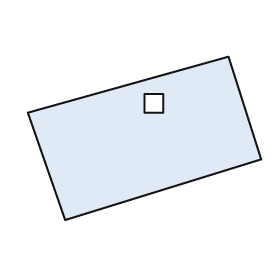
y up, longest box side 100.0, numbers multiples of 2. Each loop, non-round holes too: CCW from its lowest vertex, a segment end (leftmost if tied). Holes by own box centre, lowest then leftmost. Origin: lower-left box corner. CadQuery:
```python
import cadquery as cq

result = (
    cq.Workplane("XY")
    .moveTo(16.0, 0.0)
    .lineTo(100.0, 26.0)
    .lineTo(86.0, 70.0)
    .lineTo(0.0, 46.0)
    .close()
    .moveTo(50.0, 46.0)
    .lineTo(58.0, 46.0)
    .lineTo(58.0, 54.0)
    .lineTo(50.0, 54.0)
    .close()
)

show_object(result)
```